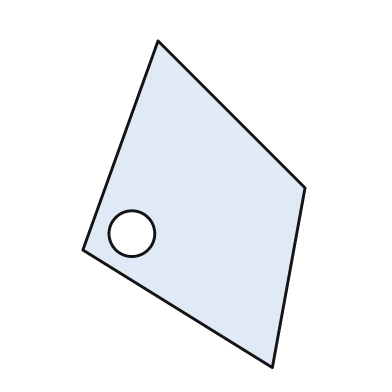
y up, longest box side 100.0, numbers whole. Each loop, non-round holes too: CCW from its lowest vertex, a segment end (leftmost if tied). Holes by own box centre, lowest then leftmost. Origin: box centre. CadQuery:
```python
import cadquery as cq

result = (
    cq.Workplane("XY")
    .moveTo(24.0, -50.0)
    .lineTo(34.0, 5.0)
    .lineTo(-11.0, 50.0)
    .lineTo(-34.0, -14.0)
    .close()
    .moveTo(-19.0, -9.0)
    .circle(7.0)
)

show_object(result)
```